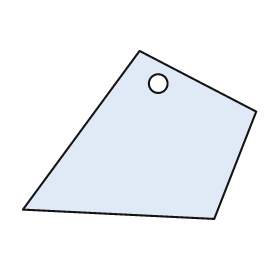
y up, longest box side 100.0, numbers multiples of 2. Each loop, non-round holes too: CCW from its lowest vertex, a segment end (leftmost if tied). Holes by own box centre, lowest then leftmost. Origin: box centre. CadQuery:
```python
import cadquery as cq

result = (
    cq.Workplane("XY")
    .moveTo(32.0, -36.0)
    .lineTo(50.0, 10.0)
    .lineTo(0.0, 36.0)
    .lineTo(-50.0, -32.0)
    .close()
    .moveTo(8.0, 22.0)
    .circle(4.0)
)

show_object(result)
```